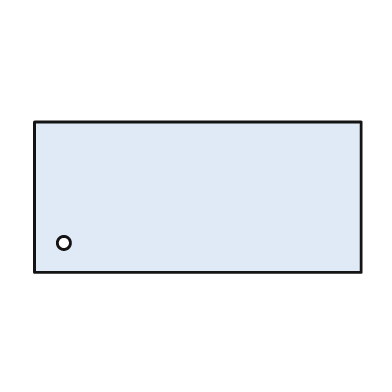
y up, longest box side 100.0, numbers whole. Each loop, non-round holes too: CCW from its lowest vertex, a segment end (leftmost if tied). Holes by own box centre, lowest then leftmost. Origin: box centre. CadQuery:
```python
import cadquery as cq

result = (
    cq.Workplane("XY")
    .moveTo(-50.0, -23.0)
    .lineTo(50.0, -23.0)
    .lineTo(50.0, 23.0)
    .lineTo(-50.0, 23.0)
    .close()
    .moveTo(-41.0, -14.0)
    .circle(2.0)
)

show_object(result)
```